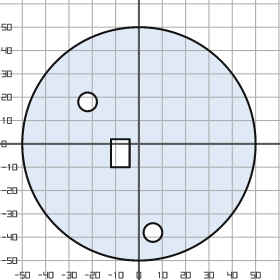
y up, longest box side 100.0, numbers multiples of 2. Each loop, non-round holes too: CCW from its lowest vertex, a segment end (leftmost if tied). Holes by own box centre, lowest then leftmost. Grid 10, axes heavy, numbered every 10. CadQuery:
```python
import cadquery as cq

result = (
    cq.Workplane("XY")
    .moveTo(0.0, 0.0)
    .circle(50.0)
    .moveTo(6.0, -38.0)
    .circle(4.0)
    .moveTo(-12.0, -10.0)
    .lineTo(-4.0, -10.0)
    .lineTo(-4.0, 2.0)
    .lineTo(-12.0, 2.0)
    .close()
    .moveTo(-22.0, 18.0)
    .circle(4.0)
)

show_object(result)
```